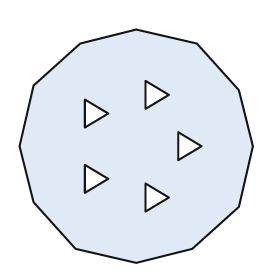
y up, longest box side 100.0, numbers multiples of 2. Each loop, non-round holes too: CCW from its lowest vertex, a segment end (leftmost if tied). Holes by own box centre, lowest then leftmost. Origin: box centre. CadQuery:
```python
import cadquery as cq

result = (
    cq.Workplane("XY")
    .moveTo(0.0, -50.0)
    .lineTo(24.0, -44.0)
    .lineTo(44.0, -26.0)
    .lineTo(50.0, 0.0)
    .lineTo(44.0, 24.0)
    .lineTo(26.0, 44.0)
    .lineTo(0.0, 50.0)
    .lineTo(-24.0, 44.0)
    .lineTo(-44.0, 26.0)
    .lineTo(-50.0, 0.0)
    .lineTo(-44.0, -24.0)
    .lineTo(-26.0, -44.0)
    .close()
    .moveTo(4.0, -28.0)
    .lineTo(14.0, -22.0)
    .lineTo(4.0, -16.0)
    .close()
    .moveTo(-22.0, -20.0)
    .lineTo(-12.0, -14.0)
    .lineTo(-22.0, -8.0)
    .close()
    .moveTo(18.0, -6.0)
    .lineTo(28.0, 0.0)
    .lineTo(18.0, 6.0)
    .close()
    .moveTo(-22.0, 8.0)
    .lineTo(-12.0, 14.0)
    .lineTo(-22.0, 20.0)
    .close()
    .moveTo(4.0, 16.0)
    .lineTo(14.0, 22.0)
    .lineTo(4.0, 28.0)
    .close()
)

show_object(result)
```